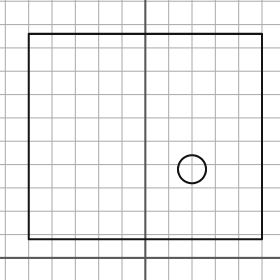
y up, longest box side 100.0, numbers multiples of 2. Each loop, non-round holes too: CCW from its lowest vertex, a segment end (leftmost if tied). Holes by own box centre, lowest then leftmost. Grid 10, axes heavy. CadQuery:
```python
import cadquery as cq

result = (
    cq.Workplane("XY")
    .moveTo(-50.0, 8.0)
    .lineTo(50.0, 8.0)
    .lineTo(50.0, 96.0)
    .lineTo(-50.0, 96.0)
    .close()
    .moveTo(20.0, 38.0)
    .circle(6.0)
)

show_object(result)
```